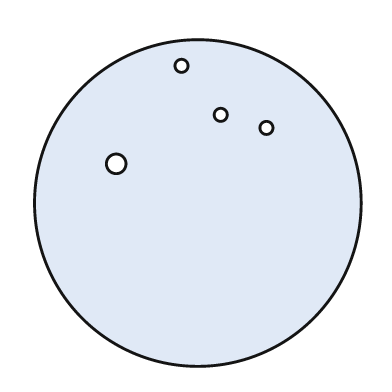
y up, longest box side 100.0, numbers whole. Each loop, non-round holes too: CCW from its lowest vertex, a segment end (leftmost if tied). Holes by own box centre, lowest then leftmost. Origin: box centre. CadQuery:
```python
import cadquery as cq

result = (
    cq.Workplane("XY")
    .moveTo(0.0, 0.0)
    .circle(50.0)
    .moveTo(-25.0, 12.0)
    .circle(3.0)
    .moveTo(21.0, 23.0)
    .circle(2.0)
    .moveTo(7.0, 27.0)
    .circle(2.0)
    .moveTo(-5.0, 42.0)
    .circle(2.0)
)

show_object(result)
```